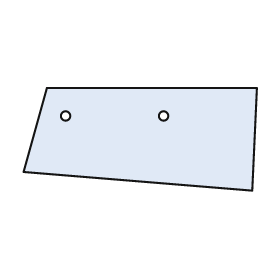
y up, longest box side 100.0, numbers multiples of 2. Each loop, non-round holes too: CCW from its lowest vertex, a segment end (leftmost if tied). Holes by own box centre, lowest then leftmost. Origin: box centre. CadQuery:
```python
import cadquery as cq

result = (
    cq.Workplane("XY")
    .moveTo(48.0, -22.0)
    .lineTo(50.0, 22.0)
    .lineTo(-40.0, 22.0)
    .lineTo(-50.0, -14.0)
    .close()
    .moveTo(-32.0, 10.0)
    .circle(2.0)
    .moveTo(10.0, 10.0)
    .circle(2.0)
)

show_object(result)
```